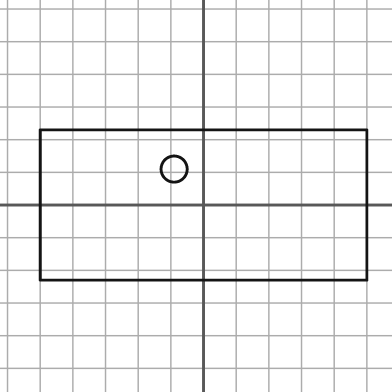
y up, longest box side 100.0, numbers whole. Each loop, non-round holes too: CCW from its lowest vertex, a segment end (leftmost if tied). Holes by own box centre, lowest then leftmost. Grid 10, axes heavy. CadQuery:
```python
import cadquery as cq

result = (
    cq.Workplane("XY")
    .moveTo(-50.0, -23.0)
    .lineTo(50.0, -23.0)
    .lineTo(50.0, 23.0)
    .lineTo(-50.0, 23.0)
    .close()
    .moveTo(-9.0, 11.0)
    .circle(4.0)
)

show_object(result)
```